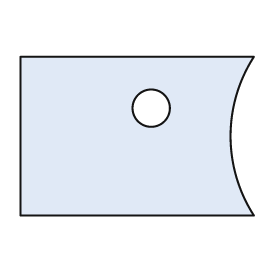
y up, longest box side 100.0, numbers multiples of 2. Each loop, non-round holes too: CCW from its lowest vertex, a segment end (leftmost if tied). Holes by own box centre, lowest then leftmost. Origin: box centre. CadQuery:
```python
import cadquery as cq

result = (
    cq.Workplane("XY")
    .moveTo(-50.0, -34.0)
    .lineTo(50.0, -34.0)
    .threePointArc((40.0, 0.0), (50.0, 34.0))
    .lineTo(-50.0, 34.0)
    .close()
    .moveTo(6.0, 12.0)
    .circle(8.0)
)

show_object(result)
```